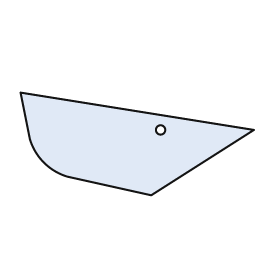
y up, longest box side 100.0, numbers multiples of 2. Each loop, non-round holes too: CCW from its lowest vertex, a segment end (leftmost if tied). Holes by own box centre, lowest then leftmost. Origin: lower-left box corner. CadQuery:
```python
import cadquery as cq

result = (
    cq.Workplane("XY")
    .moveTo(56.0, 0.0)
    .lineTo(100.0, 28.0)
    .lineTo(0.0, 44.0)
    .lineTo(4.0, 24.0)
    .threePointArc((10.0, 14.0), (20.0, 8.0))
    .close()
    .moveTo(60.0, 28.0)
    .circle(2.0)
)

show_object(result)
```